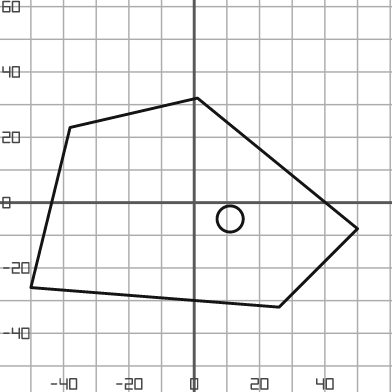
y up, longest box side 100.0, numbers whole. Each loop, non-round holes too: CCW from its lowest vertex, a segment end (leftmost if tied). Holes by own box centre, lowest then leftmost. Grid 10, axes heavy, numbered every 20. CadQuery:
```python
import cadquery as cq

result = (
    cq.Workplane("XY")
    .moveTo(26.0, -32.0)
    .lineTo(50.0, -8.0)
    .lineTo(1.0, 32.0)
    .lineTo(-38.0, 23.0)
    .lineTo(-50.0, -26.0)
    .close()
    .moveTo(11.0, -5.0)
    .circle(4.0)
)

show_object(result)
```